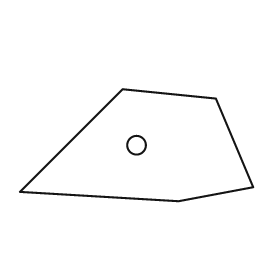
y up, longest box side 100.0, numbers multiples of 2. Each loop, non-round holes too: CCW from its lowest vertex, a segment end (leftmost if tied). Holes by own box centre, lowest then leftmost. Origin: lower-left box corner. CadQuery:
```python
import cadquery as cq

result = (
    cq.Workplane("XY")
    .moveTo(68.0, 0.0)
    .lineTo(100.0, 6.0)
    .lineTo(84.0, 44.0)
    .lineTo(44.0, 48.0)
    .lineTo(0.0, 4.0)
    .close()
    .moveTo(50.0, 24.0)
    .circle(4.0)
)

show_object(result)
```